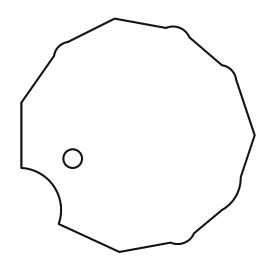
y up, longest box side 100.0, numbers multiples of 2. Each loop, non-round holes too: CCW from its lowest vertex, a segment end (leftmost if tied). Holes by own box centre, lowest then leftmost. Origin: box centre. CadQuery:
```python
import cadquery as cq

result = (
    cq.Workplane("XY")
    .moveTo(-8.0, -50.0)
    .lineTo(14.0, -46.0)
    .threePointArc((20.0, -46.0), (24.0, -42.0))
    .lineTo(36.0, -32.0)
    .threePointArc((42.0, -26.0), (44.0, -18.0))
    .lineTo(50.0, 0.0)
    .lineTo(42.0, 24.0)
    .threePointArc((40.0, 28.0), (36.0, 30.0))
    .lineTo(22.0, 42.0)
    .threePointArc((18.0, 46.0), (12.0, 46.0))
    .lineTo(-10.0, 50.0)
    .lineTo(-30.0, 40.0)
    .threePointArc((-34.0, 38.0), (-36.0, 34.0))
    .lineTo(-50.0, 14.0)
    .lineTo(-50.0, -14.0)
    .threePointArc((-36.0, -22.0), (-34.0, -38.0))
    .close()
    .moveTo(-28.0, -10.0)
    .circle(4.0)
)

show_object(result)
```